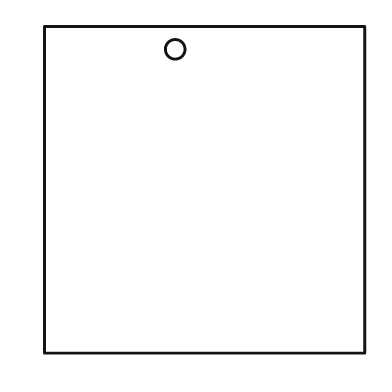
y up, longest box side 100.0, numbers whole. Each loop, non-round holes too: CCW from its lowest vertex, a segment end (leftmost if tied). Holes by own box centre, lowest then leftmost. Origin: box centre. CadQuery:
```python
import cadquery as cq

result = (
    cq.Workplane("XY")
    .moveTo(-49.0, -50.0)
    .lineTo(49.0, -50.0)
    .lineTo(49.0, 50.0)
    .lineTo(-49.0, 50.0)
    .close()
    .moveTo(-9.0, 43.0)
    .circle(3.0)
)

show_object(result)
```